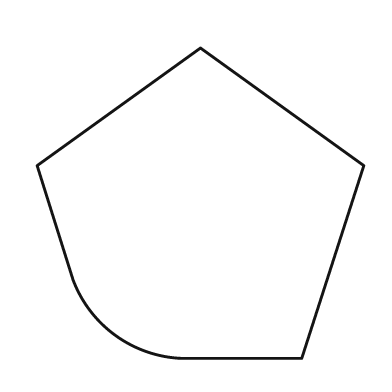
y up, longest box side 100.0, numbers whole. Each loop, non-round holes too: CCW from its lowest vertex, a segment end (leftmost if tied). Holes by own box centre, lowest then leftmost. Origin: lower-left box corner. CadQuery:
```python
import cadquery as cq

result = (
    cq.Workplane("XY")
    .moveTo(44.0, 0.0)
    .lineTo(81.0, 0.0)
    .lineTo(100.0, 59.0)
    .lineTo(50.0, 95.0)
    .lineTo(0.0, 59.0)
    .lineTo(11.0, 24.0)
    .threePointArc((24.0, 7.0), (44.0, 0.0))
    .close()
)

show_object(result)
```